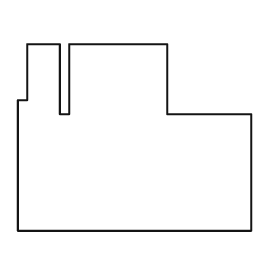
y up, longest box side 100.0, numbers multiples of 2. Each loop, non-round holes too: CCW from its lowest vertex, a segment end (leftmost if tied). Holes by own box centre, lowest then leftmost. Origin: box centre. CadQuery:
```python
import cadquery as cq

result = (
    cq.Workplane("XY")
    .moveTo(-50.0, -40.0)
    .lineTo(50.0, -40.0)
    .lineTo(50.0, 10.0)
    .lineTo(14.0, 10.0)
    .lineTo(14.0, 40.0)
    .lineTo(-28.0, 40.0)
    .lineTo(-28.0, 10.0)
    .lineTo(-32.0, 10.0)
    .lineTo(-32.0, 40.0)
    .lineTo(-46.0, 40.0)
    .lineTo(-46.0, 16.0)
    .lineTo(-50.0, 16.0)
    .close()
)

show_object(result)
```